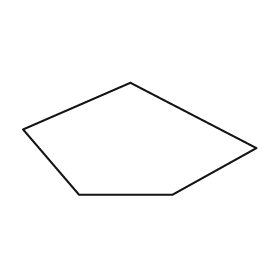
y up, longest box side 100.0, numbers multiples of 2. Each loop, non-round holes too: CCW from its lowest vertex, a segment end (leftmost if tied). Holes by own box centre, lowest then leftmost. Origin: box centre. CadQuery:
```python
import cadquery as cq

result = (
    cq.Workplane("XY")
    .moveTo(-26.0, -24.0)
    .lineTo(14.0, -24.0)
    .lineTo(50.0, -4.0)
    .lineTo(-4.0, 24.0)
    .lineTo(-50.0, 4.0)
    .close()
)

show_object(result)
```